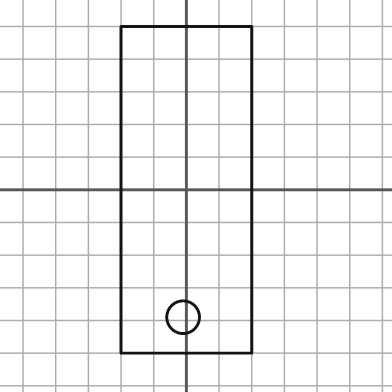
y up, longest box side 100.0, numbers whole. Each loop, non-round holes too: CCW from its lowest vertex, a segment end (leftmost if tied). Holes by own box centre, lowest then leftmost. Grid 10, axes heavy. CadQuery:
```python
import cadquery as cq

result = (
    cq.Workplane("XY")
    .moveTo(-20.0, -50.0)
    .lineTo(20.0, -50.0)
    .lineTo(20.0, 50.0)
    .lineTo(-20.0, 50.0)
    .close()
    .moveTo(-1.0, -39.0)
    .circle(5.0)
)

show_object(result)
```